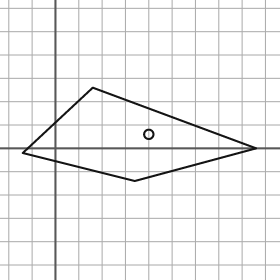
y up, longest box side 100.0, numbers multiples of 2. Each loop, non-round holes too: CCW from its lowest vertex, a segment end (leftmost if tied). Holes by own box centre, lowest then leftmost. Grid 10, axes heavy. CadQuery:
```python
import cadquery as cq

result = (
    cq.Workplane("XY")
    .moveTo(34.0, -14.0)
    .lineTo(86.0, 0.0)
    .lineTo(16.0, 26.0)
    .lineTo(-14.0, -2.0)
    .close()
    .moveTo(40.0, 6.0)
    .circle(2.0)
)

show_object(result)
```